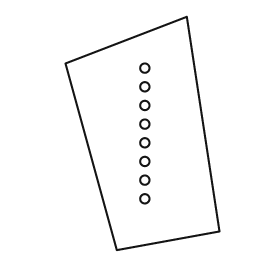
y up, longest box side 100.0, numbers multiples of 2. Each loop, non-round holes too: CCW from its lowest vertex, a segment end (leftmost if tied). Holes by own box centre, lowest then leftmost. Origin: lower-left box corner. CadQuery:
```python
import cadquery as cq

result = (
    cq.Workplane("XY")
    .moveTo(22.0, 0.0)
    .lineTo(66.0, 8.0)
    .lineTo(52.0, 100.0)
    .lineTo(0.0, 80.0)
    .close()
    .moveTo(34.0, 22.0)
    .circle(2.0)
    .moveTo(34.0, 30.0)
    .circle(2.0)
    .moveTo(34.0, 38.0)
    .circle(2.0)
    .moveTo(34.0, 46.0)
    .circle(2.0)
    .moveTo(34.0, 54.0)
    .circle(2.0)
    .moveTo(34.0, 62.0)
    .circle(2.0)
    .moveTo(34.0, 70.0)
    .circle(2.0)
    .moveTo(34.0, 78.0)
    .circle(2.0)
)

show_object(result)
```